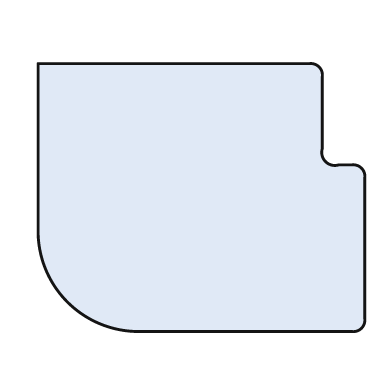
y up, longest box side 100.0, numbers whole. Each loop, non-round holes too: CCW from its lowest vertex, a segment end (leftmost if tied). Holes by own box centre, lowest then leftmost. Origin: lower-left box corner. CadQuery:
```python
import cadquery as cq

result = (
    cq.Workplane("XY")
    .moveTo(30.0, 0.0)
    .lineTo(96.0, 0.0)
    .threePointArc((99.0, 1.0), (100.0, 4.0))
    .lineTo(100.0, 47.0)
    .threePointArc((99.0, 50.0), (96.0, 51.0))
    .lineTo(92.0, 51.0)
    .threePointArc((88.0, 52.0), (87.0, 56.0))
    .lineTo(87.0, 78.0)
    .threePointArc((86.0, 81.0), (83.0, 82.0))
    .lineTo(0.0, 82.0)
    .lineTo(0.0, 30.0)
    .threePointArc((9.0, 9.0), (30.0, 0.0))
    .close()
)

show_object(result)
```